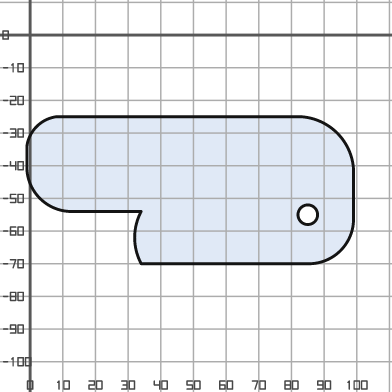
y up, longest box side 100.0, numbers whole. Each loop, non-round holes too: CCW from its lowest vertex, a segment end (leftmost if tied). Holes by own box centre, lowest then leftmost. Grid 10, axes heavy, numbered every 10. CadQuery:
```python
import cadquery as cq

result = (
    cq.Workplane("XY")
    .moveTo(34.0, -70.0)
    .lineTo(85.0, -70.0)
    .threePointArc((95.0, -66.0), (99.0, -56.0))
    .lineTo(99.0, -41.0)
    .threePointArc((94.0, -30.0), (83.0, -25.0))
    .lineTo(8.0, -25.0)
    .threePointArc((2.0, -28.0), (-1.0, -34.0))
    .lineTo(-1.0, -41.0)
    .threePointArc((3.0, -50.0), (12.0, -54.0))
    .lineTo(34.0, -54.0)
    .threePointArc((32.0, -62.0), (34.0, -70.0))
    .close()
    .moveTo(85.0, -55.0)
    .circle(3.0)
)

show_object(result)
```